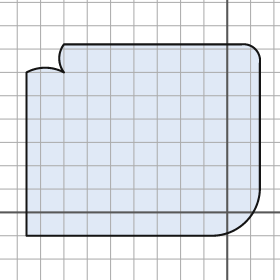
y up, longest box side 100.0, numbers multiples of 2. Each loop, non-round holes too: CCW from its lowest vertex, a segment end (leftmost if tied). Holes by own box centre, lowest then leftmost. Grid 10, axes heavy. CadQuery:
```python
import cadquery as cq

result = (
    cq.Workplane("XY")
    .moveTo(-86.0, -10.0)
    .lineTo(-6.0, -10.0)
    .threePointArc((8.0, -4.0), (14.0, 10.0))
    .lineTo(14.0, 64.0)
    .threePointArc((12.0, 70.0), (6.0, 72.0))
    .lineTo(-70.0, 72.0)
    .threePointArc((-72.0, 66.0), (-70.0, 60.0))
    .threePointArc((-78.0, 62.0), (-86.0, 60.0))
    .close()
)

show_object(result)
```